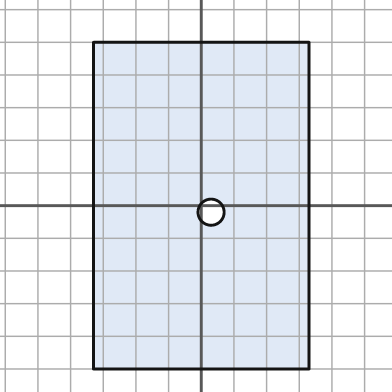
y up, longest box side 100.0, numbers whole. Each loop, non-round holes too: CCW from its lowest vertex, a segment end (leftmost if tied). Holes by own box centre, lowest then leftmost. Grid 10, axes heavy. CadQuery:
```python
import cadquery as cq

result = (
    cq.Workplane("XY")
    .moveTo(-33.0, -50.0)
    .lineTo(33.0, -50.0)
    .lineTo(33.0, 50.0)
    .lineTo(-33.0, 50.0)
    .close()
    .moveTo(3.0, -2.0)
    .circle(4.0)
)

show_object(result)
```